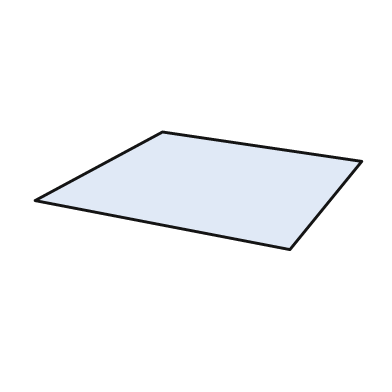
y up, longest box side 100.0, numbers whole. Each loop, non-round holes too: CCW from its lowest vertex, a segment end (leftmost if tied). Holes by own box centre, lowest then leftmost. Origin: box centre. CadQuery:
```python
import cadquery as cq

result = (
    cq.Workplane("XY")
    .moveTo(28.0, -18.0)
    .lineTo(50.0, 9.0)
    .lineTo(-11.0, 18.0)
    .lineTo(-50.0, -3.0)
    .close()
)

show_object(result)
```